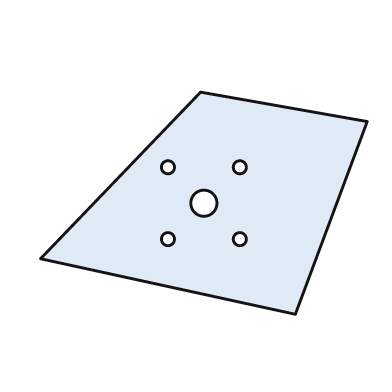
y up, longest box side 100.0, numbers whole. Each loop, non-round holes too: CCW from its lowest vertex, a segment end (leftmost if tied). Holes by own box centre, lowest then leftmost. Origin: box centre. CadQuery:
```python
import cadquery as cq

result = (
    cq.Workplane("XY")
    .moveTo(28.0, -34.0)
    .lineTo(50.0, 25.0)
    .lineTo(-1.0, 34.0)
    .lineTo(-50.0, -17.0)
    .close()
    .moveTo(-11.0, -11.0)
    .circle(2.0)
    .moveTo(11.0, -11.0)
    .circle(2.0)
    .moveTo(0.0, 0.0)
    .circle(4.0)
    .moveTo(-11.0, 11.0)
    .circle(2.0)
    .moveTo(11.0, 11.0)
    .circle(2.0)
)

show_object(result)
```